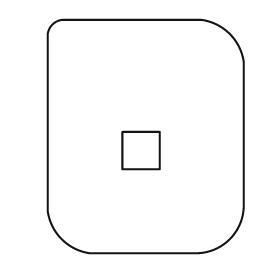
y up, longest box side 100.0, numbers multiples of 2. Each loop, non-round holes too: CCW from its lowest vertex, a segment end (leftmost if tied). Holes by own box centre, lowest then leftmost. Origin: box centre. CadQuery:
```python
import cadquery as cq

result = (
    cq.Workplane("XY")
    .moveTo(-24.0, -50.0)
    .lineTo(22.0, -50.0)
    .threePointArc((36.0, -44.0), (42.0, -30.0))
    .lineTo(42.0, 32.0)
    .threePointArc((36.0, 44.0), (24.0, 50.0))
    .lineTo(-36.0, 50.0)
    .threePointArc((-40.0, 48.0), (-42.0, 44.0))
    .lineTo(-42.0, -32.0)
    .threePointArc((-36.0, -44.0), (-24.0, -50.0))
    .close()
    .moveTo(-10.0, -14.0)
    .lineTo(6.0, -14.0)
    .lineTo(6.0, 2.0)
    .lineTo(-10.0, 2.0)
    .close()
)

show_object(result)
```